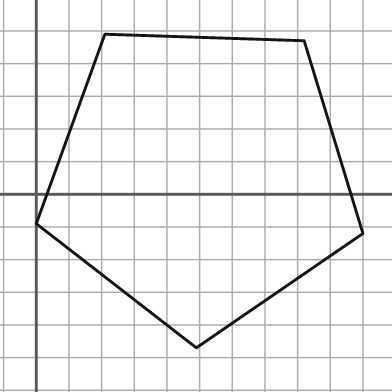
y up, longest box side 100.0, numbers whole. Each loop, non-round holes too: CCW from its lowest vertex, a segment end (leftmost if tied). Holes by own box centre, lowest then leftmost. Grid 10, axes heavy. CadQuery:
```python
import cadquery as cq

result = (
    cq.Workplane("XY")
    .moveTo(49.0, -47.0)
    .lineTo(100.0, -12.0)
    .lineTo(82.0, 47.0)
    .lineTo(21.0, 49.0)
    .lineTo(0.0, -9.0)
    .close()
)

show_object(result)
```